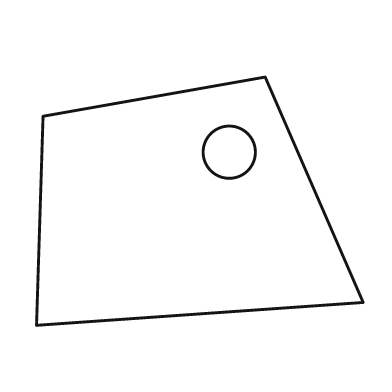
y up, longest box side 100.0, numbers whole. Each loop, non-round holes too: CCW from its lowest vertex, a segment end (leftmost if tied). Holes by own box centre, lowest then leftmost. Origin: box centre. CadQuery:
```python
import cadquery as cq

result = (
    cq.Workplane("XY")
    .moveTo(-50.0, -38.0)
    .lineTo(50.0, -31.0)
    .lineTo(20.0, 38.0)
    .lineTo(-48.0, 26.0)
    .close()
    .moveTo(9.0, 15.0)
    .circle(8.0)
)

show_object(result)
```